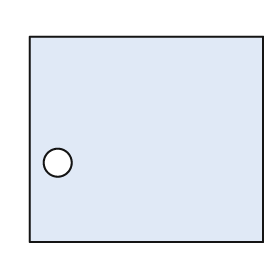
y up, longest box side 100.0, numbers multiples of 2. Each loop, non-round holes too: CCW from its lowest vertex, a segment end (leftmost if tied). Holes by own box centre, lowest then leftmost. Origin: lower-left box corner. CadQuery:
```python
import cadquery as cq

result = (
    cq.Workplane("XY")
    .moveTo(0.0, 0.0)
    .lineTo(100.0, 0.0)
    .lineTo(100.0, 88.0)
    .lineTo(0.0, 88.0)
    .close()
    .moveTo(12.0, 34.0)
    .circle(6.0)
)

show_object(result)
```